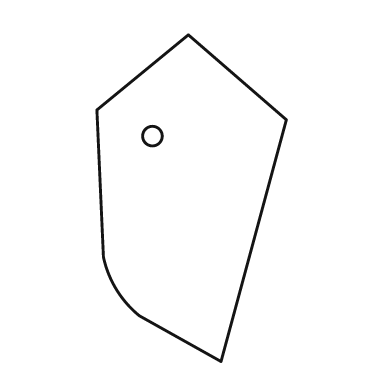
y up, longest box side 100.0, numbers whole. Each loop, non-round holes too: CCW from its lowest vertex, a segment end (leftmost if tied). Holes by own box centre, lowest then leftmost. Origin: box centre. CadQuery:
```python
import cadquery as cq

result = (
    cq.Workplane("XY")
    .moveTo(9.0, -50.0)
    .lineTo(29.0, 24.0)
    .lineTo(-1.0, 50.0)
    .lineTo(-29.0, 27.0)
    .lineTo(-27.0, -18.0)
    .threePointArc((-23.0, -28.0), (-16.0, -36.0))
    .close()
    .moveTo(-12.0, 19.0)
    .circle(3.0)
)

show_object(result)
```